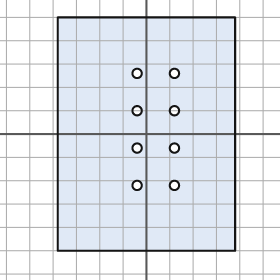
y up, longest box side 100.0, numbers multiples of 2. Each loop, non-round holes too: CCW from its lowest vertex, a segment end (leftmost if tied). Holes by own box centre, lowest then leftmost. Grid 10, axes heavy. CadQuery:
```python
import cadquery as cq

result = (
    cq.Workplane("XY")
    .moveTo(-38.0, -50.0)
    .lineTo(38.0, -50.0)
    .lineTo(38.0, 50.0)
    .lineTo(-38.0, 50.0)
    .close()
    .moveTo(-4.0, -22.0)
    .circle(2.0)
    .moveTo(12.0, -22.0)
    .circle(2.0)
    .moveTo(-4.0, -6.0)
    .circle(2.0)
    .moveTo(12.0, -6.0)
    .circle(2.0)
    .moveTo(-4.0, 10.0)
    .circle(2.0)
    .moveTo(12.0, 10.0)
    .circle(2.0)
    .moveTo(-4.0, 26.0)
    .circle(2.0)
    .moveTo(12.0, 26.0)
    .circle(2.0)
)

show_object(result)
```